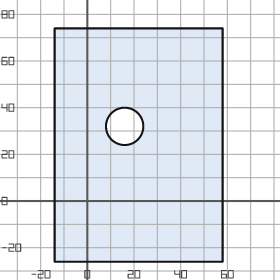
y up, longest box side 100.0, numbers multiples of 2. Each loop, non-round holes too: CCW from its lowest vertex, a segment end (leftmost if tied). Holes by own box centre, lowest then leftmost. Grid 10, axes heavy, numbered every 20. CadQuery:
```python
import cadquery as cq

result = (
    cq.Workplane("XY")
    .moveTo(-14.0, -26.0)
    .lineTo(58.0, -26.0)
    .lineTo(58.0, 74.0)
    .lineTo(-14.0, 74.0)
    .close()
    .moveTo(16.0, 32.0)
    .circle(8.0)
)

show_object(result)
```